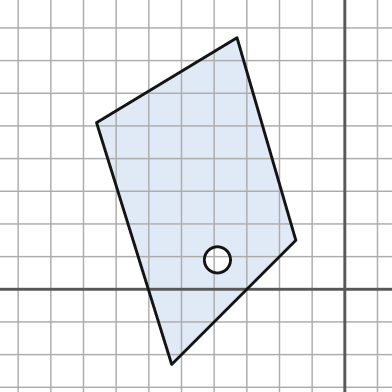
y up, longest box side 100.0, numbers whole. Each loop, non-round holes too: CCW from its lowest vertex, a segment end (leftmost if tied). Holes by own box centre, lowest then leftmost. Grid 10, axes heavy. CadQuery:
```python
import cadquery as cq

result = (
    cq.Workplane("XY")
    .moveTo(-53.0, -23.0)
    .lineTo(-15.0, 15.0)
    .lineTo(-33.0, 77.0)
    .lineTo(-76.0, 51.0)
    .close()
    .moveTo(-39.0, 9.0)
    .circle(4.0)
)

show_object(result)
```